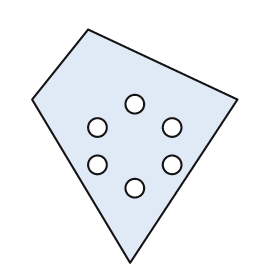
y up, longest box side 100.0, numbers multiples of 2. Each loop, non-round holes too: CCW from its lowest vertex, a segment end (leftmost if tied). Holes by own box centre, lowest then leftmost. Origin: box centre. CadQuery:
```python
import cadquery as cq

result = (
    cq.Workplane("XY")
    .moveTo(-2.0, -50.0)
    .lineTo(44.0, 20.0)
    .lineTo(-20.0, 50.0)
    .lineTo(-44.0, 20.0)
    .close()
    .moveTo(0.0, -18.0)
    .circle(4.0)
    .moveTo(-16.0, -8.0)
    .circle(4.0)
    .moveTo(16.0, -8.0)
    .circle(4.0)
    .moveTo(-16.0, 8.0)
    .circle(4.0)
    .moveTo(16.0, 8.0)
    .circle(4.0)
    .moveTo(0.0, 18.0)
    .circle(4.0)
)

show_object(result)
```